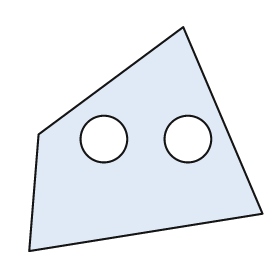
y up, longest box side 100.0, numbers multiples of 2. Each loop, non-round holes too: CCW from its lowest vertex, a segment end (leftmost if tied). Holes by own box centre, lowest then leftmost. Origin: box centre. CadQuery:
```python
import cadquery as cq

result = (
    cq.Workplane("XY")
    .moveTo(-50.0, -48.0)
    .lineTo(50.0, -32.0)
    .lineTo(16.0, 48.0)
    .lineTo(-46.0, 2.0)
    .close()
    .moveTo(-18.0, 0.0)
    .circle(10.0)
    .moveTo(18.0, 0.0)
    .circle(10.0)
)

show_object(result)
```